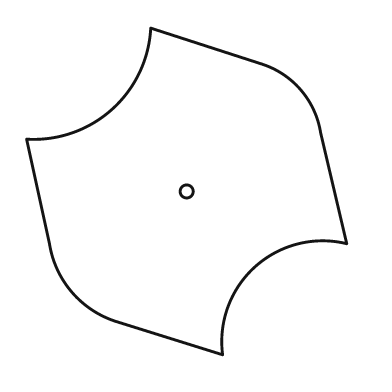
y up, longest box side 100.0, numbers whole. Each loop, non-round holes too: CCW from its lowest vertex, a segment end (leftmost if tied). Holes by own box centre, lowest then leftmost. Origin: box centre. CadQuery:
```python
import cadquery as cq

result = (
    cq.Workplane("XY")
    .moveTo(11.0, -50.0)
    .threePointArc((21.0, -23.0), (49.0, -16.0))
    .lineTo(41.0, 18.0)
    .threePointArc((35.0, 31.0), (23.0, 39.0))
    .lineTo(-11.0, 50.0)
    .threePointArc((-23.0, 25.0), (-49.0, 16.0))
    .lineTo(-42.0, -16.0)
    .threePointArc((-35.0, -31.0), (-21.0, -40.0))
    .close()
    .moveTo(0.0, 0.0)
    .circle(2.0)
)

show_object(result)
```